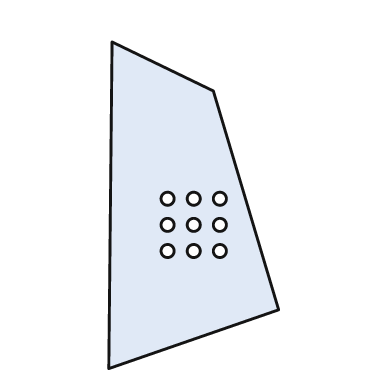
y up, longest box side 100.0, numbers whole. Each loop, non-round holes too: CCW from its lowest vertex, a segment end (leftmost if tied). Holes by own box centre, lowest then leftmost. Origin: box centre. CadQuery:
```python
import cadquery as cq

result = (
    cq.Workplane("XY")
    .moveTo(-26.0, -50.0)
    .lineTo(26.0, -32.0)
    .lineTo(6.0, 35.0)
    .lineTo(-25.0, 50.0)
    .close()
    .moveTo(-8.0, -14.0)
    .circle(2.0)
    .moveTo(0.0, -14.0)
    .circle(2.0)
    .moveTo(8.0, -14.0)
    .circle(2.0)
    .moveTo(-8.0, -6.0)
    .circle(2.0)
    .moveTo(0.0, -6.0)
    .circle(2.0)
    .moveTo(8.0, -6.0)
    .circle(2.0)
    .moveTo(-8.0, 2.0)
    .circle(2.0)
    .moveTo(0.0, 2.0)
    .circle(2.0)
    .moveTo(8.0, 2.0)
    .circle(2.0)
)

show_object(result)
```